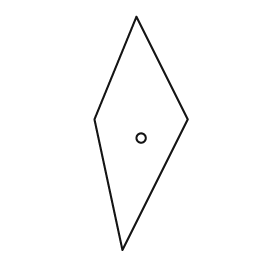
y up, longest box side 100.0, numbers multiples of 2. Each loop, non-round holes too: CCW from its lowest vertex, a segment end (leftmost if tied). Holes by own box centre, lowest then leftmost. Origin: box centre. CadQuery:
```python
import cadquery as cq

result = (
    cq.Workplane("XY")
    .moveTo(-8.0, -50.0)
    .lineTo(20.0, 6.0)
    .lineTo(-2.0, 50.0)
    .lineTo(-20.0, 6.0)
    .close()
    .moveTo(0.0, -2.0)
    .circle(2.0)
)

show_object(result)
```